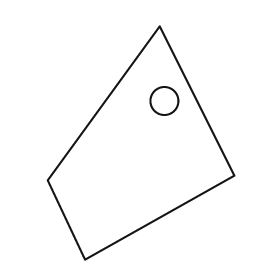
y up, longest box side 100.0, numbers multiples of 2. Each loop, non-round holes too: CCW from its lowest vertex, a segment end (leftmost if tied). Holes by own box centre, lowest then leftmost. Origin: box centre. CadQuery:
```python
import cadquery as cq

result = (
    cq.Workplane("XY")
    .moveTo(-24.0, -50.0)
    .lineTo(40.0, -14.0)
    .lineTo(8.0, 50.0)
    .lineTo(-40.0, -16.0)
    .close()
    .moveTo(10.0, 18.0)
    .circle(6.0)
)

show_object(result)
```